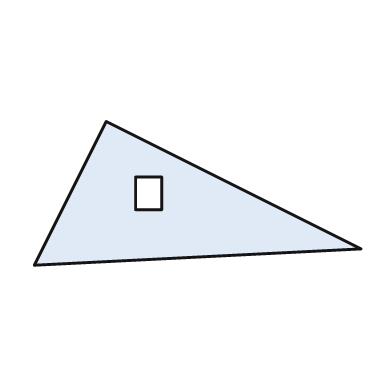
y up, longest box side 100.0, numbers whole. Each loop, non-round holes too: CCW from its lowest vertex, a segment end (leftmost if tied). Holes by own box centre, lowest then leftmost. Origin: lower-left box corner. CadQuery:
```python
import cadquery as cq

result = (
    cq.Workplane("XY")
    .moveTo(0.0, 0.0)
    .lineTo(100.0, 5.0)
    .lineTo(22.0, 44.0)
    .close()
    .moveTo(31.0, 17.0)
    .lineTo(39.0, 17.0)
    .lineTo(39.0, 27.0)
    .lineTo(31.0, 27.0)
    .close()
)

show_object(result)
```